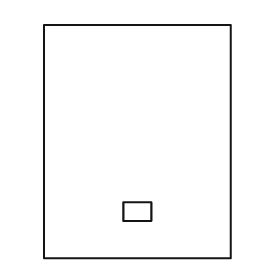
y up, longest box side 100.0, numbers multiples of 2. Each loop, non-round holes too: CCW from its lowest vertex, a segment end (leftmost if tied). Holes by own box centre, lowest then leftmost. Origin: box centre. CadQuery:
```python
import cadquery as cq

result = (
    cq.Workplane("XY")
    .moveTo(-40.0, -50.0)
    .lineTo(40.0, -50.0)
    .lineTo(40.0, 50.0)
    .lineTo(-40.0, 50.0)
    .close()
    .moveTo(-6.0, -34.0)
    .lineTo(6.0, -34.0)
    .lineTo(6.0, -26.0)
    .lineTo(-6.0, -26.0)
    .close()
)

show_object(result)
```